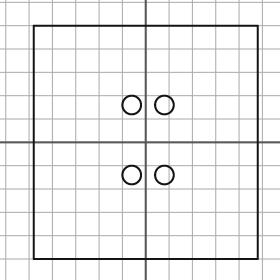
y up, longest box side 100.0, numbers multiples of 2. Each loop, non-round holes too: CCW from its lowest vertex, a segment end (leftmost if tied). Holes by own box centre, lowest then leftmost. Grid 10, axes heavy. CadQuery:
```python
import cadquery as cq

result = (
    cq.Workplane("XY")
    .moveTo(-48.0, -50.0)
    .lineTo(48.0, -50.0)
    .lineTo(48.0, 50.0)
    .lineTo(-48.0, 50.0)
    .close()
    .moveTo(-6.0, -14.0)
    .circle(4.0)
    .moveTo(8.0, -14.0)
    .circle(4.0)
    .moveTo(-6.0, 16.0)
    .circle(4.0)
    .moveTo(8.0, 16.0)
    .circle(4.0)
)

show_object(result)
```